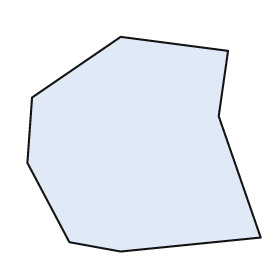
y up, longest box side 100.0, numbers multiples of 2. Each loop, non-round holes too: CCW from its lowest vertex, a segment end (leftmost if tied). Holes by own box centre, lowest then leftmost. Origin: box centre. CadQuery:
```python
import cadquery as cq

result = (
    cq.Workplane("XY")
    .moveTo(-10.0, -46.0)
    .lineTo(50.0, -40.0)
    .lineTo(32.0, 12.0)
    .lineTo(36.0, 40.0)
    .lineTo(-10.0, 46.0)
    .lineTo(-48.0, 20.0)
    .lineTo(-50.0, -8.0)
    .lineTo(-32.0, -42.0)
    .close()
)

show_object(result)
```